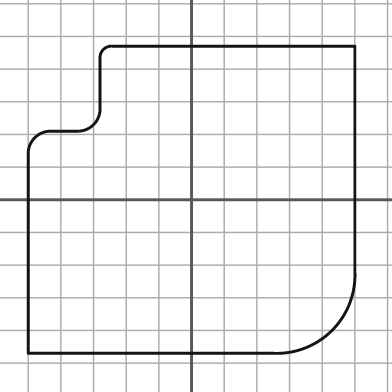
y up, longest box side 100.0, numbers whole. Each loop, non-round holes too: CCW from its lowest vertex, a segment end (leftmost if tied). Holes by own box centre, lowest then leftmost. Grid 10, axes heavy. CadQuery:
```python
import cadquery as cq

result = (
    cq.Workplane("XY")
    .moveTo(-50.0, -47.0)
    .lineTo(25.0, -47.0)
    .threePointArc((43.0, -40.0), (50.0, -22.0))
    .lineTo(50.0, 47.0)
    .lineTo(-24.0, 47.0)
    .threePointArc((-27.0, 46.0), (-28.0, 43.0))
    .lineTo(-28.0, 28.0)
    .threePointArc((-30.0, 23.0), (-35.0, 21.0))
    .lineTo(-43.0, 21.0)
    .threePointArc((-48.0, 19.0), (-50.0, 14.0))
    .close()
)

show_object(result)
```